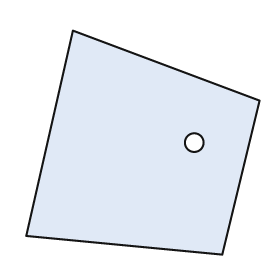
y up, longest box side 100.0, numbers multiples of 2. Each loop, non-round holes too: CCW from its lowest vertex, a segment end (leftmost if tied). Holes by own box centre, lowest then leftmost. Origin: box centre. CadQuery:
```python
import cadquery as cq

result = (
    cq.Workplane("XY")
    .moveTo(34.0, -48.0)
    .lineTo(50.0, 18.0)
    .lineTo(-30.0, 48.0)
    .lineTo(-50.0, -40.0)
    .close()
    .moveTo(22.0, 0.0)
    .circle(4.0)
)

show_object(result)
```